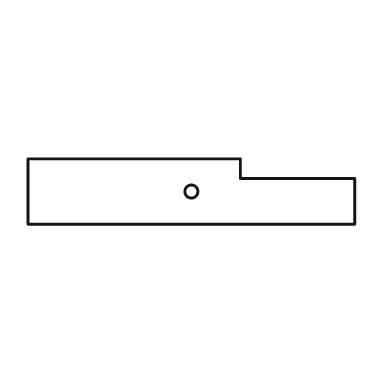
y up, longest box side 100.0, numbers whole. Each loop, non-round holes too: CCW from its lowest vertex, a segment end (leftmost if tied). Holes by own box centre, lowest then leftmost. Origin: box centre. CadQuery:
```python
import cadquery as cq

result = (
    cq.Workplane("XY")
    .moveTo(-50.0, -10.0)
    .lineTo(50.0, -10.0)
    .lineTo(50.0, 4.0)
    .lineTo(15.0, 4.0)
    .lineTo(15.0, 10.0)
    .lineTo(-50.0, 10.0)
    .close()
    .moveTo(0.0, 0.0)
    .circle(2.0)
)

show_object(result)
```